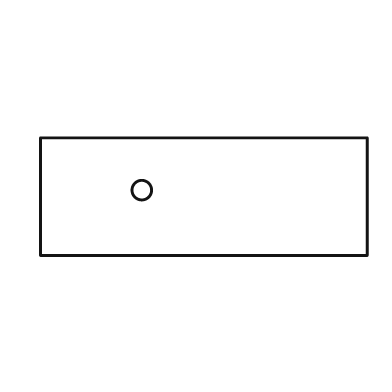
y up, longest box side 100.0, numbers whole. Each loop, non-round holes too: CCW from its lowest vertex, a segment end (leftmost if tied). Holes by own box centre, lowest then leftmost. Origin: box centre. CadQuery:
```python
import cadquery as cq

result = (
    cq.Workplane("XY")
    .moveTo(-50.0, -18.0)
    .lineTo(50.0, -18.0)
    .lineTo(50.0, 18.0)
    .lineTo(-50.0, 18.0)
    .close()
    .moveTo(-19.0, 2.0)
    .circle(3.0)
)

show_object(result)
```